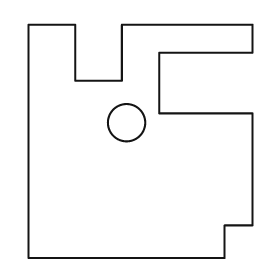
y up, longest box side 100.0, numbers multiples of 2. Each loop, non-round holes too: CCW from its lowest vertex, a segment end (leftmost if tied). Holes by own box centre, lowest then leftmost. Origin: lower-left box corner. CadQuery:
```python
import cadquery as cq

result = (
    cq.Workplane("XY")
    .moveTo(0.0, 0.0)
    .lineTo(84.0, 0.0)
    .lineTo(84.0, 14.0)
    .lineTo(96.0, 14.0)
    .lineTo(96.0, 62.0)
    .lineTo(56.0, 62.0)
    .lineTo(56.0, 88.0)
    .lineTo(96.0, 88.0)
    .lineTo(96.0, 100.0)
    .lineTo(40.0, 100.0)
    .lineTo(40.0, 76.0)
    .lineTo(20.0, 76.0)
    .lineTo(20.0, 100.0)
    .lineTo(0.0, 100.0)
    .close()
    .moveTo(42.0, 58.0)
    .circle(8.0)
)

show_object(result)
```